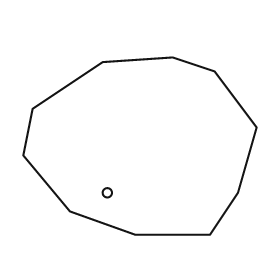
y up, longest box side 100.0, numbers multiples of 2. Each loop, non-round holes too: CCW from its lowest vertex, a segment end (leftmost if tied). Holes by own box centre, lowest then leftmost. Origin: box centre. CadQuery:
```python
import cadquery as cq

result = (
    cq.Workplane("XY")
    .moveTo(-2.0, -38.0)
    .lineTo(30.0, -38.0)
    .lineTo(42.0, -20.0)
    .lineTo(50.0, 8.0)
    .lineTo(32.0, 32.0)
    .lineTo(14.0, 38.0)
    .lineTo(-16.0, 36.0)
    .lineTo(-46.0, 16.0)
    .lineTo(-50.0, -4.0)
    .lineTo(-30.0, -28.0)
    .close()
    .moveTo(-14.0, -20.0)
    .circle(2.0)
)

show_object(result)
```